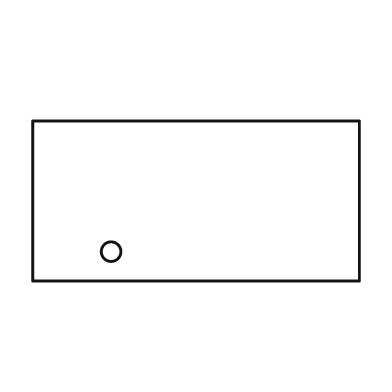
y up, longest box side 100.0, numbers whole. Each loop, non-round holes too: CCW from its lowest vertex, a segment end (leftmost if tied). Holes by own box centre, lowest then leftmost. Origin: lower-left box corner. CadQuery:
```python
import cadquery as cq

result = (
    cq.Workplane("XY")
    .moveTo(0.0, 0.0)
    .lineTo(100.0, 0.0)
    .lineTo(100.0, 49.0)
    .lineTo(0.0, 49.0)
    .close()
    .moveTo(24.0, 9.0)
    .circle(3.0)
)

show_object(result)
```